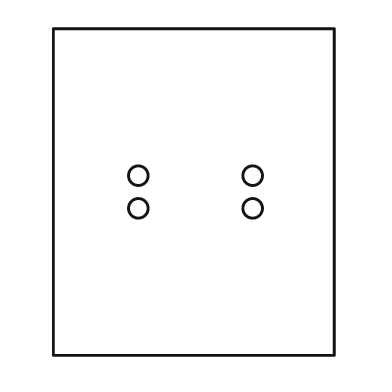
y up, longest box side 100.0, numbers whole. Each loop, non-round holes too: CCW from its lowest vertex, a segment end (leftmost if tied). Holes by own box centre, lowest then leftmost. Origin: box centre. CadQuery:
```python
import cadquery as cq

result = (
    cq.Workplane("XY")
    .moveTo(-43.0, -50.0)
    .lineTo(43.0, -50.0)
    .lineTo(43.0, 50.0)
    .lineTo(-43.0, 50.0)
    .close()
    .moveTo(-17.0, -5.0)
    .circle(3.0)
    .moveTo(18.0, -5.0)
    .circle(3.0)
    .moveTo(-17.0, 5.0)
    .circle(3.0)
    .moveTo(18.0, 5.0)
    .circle(3.0)
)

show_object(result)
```